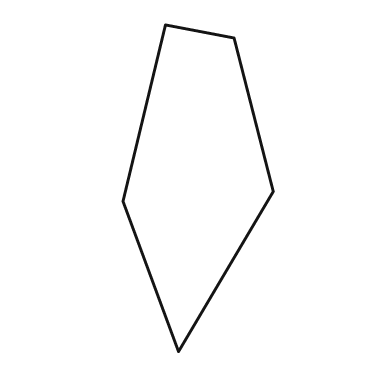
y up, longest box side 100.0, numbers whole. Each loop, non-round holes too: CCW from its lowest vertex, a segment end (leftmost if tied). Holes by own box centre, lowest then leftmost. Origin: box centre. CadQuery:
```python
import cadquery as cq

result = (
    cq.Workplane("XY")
    .moveTo(-6.0, -50.0)
    .lineTo(23.0, -1.0)
    .lineTo(11.0, 46.0)
    .lineTo(-10.0, 50.0)
    .lineTo(-23.0, -4.0)
    .close()
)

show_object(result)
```